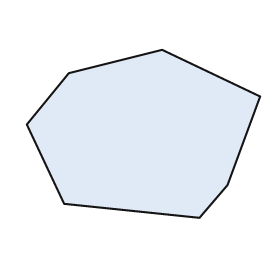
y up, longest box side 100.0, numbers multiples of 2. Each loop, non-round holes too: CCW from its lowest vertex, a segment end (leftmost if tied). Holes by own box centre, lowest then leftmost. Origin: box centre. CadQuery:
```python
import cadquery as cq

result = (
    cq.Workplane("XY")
    .moveTo(24.0, -36.0)
    .lineTo(36.0, -22.0)
    .lineTo(50.0, 16.0)
    .lineTo(8.0, 36.0)
    .lineTo(-32.0, 26.0)
    .lineTo(-50.0, 4.0)
    .lineTo(-34.0, -30.0)
    .close()
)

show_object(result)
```